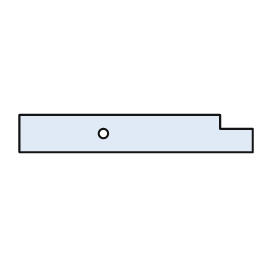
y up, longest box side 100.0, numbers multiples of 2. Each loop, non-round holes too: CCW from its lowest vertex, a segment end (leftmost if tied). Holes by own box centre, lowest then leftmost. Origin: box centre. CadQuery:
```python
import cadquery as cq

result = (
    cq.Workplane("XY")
    .moveTo(-50.0, -8.0)
    .lineTo(50.0, -8.0)
    .lineTo(50.0, 2.0)
    .lineTo(36.0, 2.0)
    .lineTo(36.0, 8.0)
    .lineTo(-50.0, 8.0)
    .close()
    .moveTo(-14.0, 0.0)
    .circle(2.0)
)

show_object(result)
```